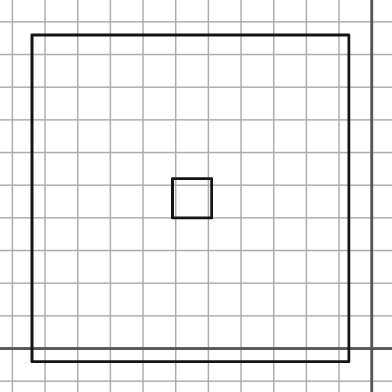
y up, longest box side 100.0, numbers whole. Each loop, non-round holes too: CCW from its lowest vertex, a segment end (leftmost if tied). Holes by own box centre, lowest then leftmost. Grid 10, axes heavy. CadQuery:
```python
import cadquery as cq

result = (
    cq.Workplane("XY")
    .moveTo(-104.0, -4.0)
    .lineTo(-7.0, -4.0)
    .lineTo(-7.0, 96.0)
    .lineTo(-104.0, 96.0)
    .close()
    .moveTo(-61.0, 40.0)
    .lineTo(-49.0, 40.0)
    .lineTo(-49.0, 52.0)
    .lineTo(-61.0, 52.0)
    .close()
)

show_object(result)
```